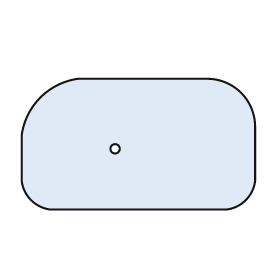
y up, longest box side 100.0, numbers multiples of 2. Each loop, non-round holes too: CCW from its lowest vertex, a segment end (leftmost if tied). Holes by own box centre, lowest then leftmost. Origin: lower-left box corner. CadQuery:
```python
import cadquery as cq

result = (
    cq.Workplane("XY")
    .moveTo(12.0, 0.0)
    .lineTo(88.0, 0.0)
    .threePointArc((96.0, 4.0), (100.0, 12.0))
    .lineTo(100.0, 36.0)
    .threePointArc((94.0, 50.0), (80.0, 56.0))
    .lineTo(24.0, 56.0)
    .threePointArc((8.0, 48.0), (0.0, 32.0))
    .lineTo(0.0, 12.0)
    .threePointArc((4.0, 4.0), (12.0, 0.0))
    .close()
    .moveTo(40.0, 26.0)
    .circle(2.0)
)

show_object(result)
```